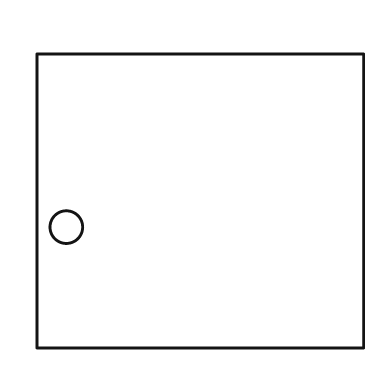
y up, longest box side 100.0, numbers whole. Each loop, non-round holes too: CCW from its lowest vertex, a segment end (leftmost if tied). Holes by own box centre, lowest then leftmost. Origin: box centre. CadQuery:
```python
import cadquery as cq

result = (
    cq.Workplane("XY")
    .moveTo(-50.0, -45.0)
    .lineTo(50.0, -45.0)
    .lineTo(50.0, 45.0)
    .lineTo(-50.0, 45.0)
    .close()
    .moveTo(-41.0, -8.0)
    .circle(5.0)
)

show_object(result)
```